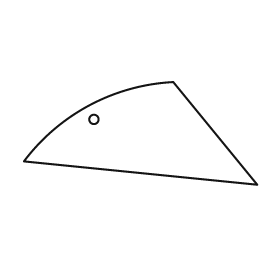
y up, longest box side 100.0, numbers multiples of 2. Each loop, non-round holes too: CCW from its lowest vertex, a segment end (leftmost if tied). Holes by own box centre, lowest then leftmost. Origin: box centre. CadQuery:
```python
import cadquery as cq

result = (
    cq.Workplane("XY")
    .moveTo(50.0, -22.0)
    .lineTo(14.0, 22.0)
    .threePointArc((-22.0, 12.0), (-50.0, -12.0))
    .close()
    .moveTo(-20.0, 6.0)
    .circle(2.0)
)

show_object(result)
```